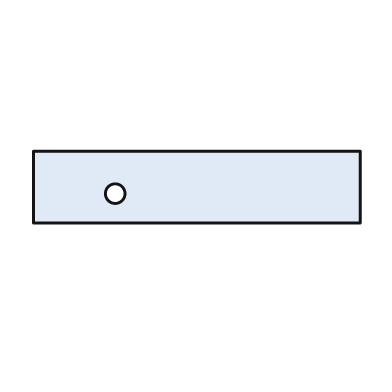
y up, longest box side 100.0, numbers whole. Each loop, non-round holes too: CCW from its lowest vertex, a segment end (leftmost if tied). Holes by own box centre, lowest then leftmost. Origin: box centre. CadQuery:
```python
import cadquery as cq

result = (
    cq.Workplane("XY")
    .moveTo(-50.0, -11.0)
    .lineTo(50.0, -11.0)
    .lineTo(50.0, 11.0)
    .lineTo(-50.0, 11.0)
    .close()
    .moveTo(-25.0, -2.0)
    .circle(3.0)
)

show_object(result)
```